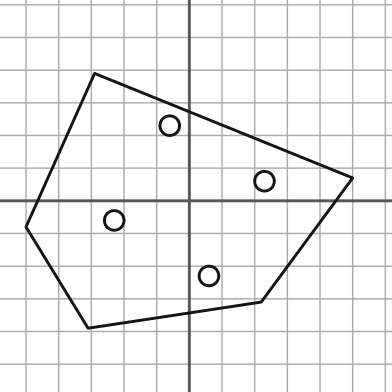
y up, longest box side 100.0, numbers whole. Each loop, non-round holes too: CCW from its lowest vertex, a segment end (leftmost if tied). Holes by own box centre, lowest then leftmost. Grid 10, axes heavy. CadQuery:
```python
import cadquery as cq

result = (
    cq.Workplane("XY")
    .moveTo(-31.0, -39.0)
    .lineTo(22.0, -31.0)
    .lineTo(50.0, 7.0)
    .lineTo(-29.0, 39.0)
    .lineTo(-50.0, -8.0)
    .close()
    .moveTo(6.0, -23.0)
    .circle(3.0)
    .moveTo(-23.0, -6.0)
    .circle(3.0)
    .moveTo(23.0, 6.0)
    .circle(3.0)
    .moveTo(-6.0, 23.0)
    .circle(3.0)
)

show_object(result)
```